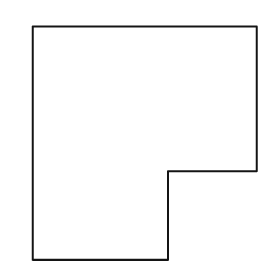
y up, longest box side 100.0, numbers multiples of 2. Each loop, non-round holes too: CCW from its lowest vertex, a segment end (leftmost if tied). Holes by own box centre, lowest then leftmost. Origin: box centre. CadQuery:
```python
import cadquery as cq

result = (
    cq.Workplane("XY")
    .moveTo(-48.0, -50.0)
    .lineTo(10.0, -50.0)
    .lineTo(10.0, -12.0)
    .lineTo(48.0, -12.0)
    .lineTo(48.0, 50.0)
    .lineTo(-48.0, 50.0)
    .close()
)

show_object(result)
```